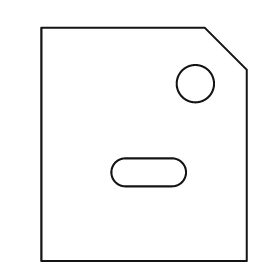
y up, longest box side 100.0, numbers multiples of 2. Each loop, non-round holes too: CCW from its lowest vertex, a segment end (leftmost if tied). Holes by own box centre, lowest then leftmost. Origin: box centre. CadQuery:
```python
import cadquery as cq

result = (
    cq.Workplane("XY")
    .moveTo(-44.0, -50.0)
    .lineTo(44.0, -50.0)
    .lineTo(44.0, 32.0)
    .lineTo(26.0, 50.0)
    .lineTo(-44.0, 50.0)
    .close()
    .moveTo(-8.0, -18.0)
    .lineTo(12.0, -18.0)
    .threePointArc((18.0, -12.0), (12.0, -6.0))
    .lineTo(-8.0, -6.0)
    .threePointArc((-14.0, -12.0), (-8.0, -18.0))
    .close()
    .moveTo(22.0, 26.0)
    .circle(8.0)
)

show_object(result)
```